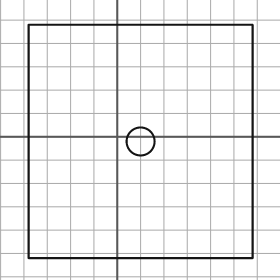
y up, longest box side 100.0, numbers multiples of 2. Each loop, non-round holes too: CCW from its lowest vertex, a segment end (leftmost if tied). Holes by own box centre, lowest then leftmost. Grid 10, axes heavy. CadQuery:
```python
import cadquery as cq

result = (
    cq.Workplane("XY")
    .moveTo(-38.0, -52.0)
    .lineTo(58.0, -52.0)
    .lineTo(58.0, 48.0)
    .lineTo(-38.0, 48.0)
    .close()
    .moveTo(10.0, -2.0)
    .circle(6.0)
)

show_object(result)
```